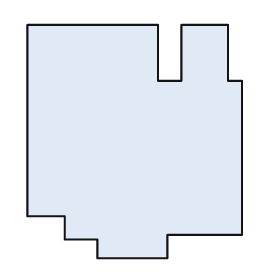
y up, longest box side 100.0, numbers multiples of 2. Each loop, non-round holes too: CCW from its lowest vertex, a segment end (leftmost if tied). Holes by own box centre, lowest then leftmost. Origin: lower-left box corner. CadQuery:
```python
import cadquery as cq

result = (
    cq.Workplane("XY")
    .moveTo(30.0, 0.0)
    .lineTo(60.0, 0.0)
    .lineTo(60.0, 10.0)
    .lineTo(92.0, 10.0)
    .lineTo(92.0, 76.0)
    .lineTo(86.0, 76.0)
    .lineTo(86.0, 100.0)
    .lineTo(66.0, 100.0)
    .lineTo(66.0, 76.0)
    .lineTo(56.0, 76.0)
    .lineTo(56.0, 100.0)
    .lineTo(0.0, 100.0)
    .lineTo(0.0, 18.0)
    .lineTo(16.0, 18.0)
    .lineTo(16.0, 8.0)
    .lineTo(30.0, 8.0)
    .close()
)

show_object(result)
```